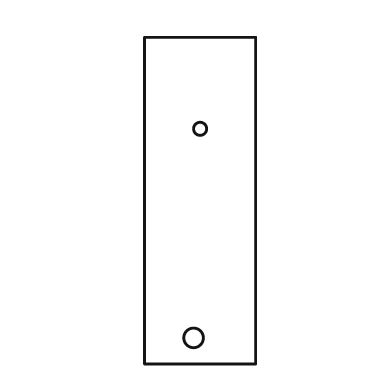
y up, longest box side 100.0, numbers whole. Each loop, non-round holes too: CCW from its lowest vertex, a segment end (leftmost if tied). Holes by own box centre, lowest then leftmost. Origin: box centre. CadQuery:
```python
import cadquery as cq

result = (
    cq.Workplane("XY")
    .moveTo(-17.0, -50.0)
    .lineTo(17.0, -50.0)
    .lineTo(17.0, 50.0)
    .lineTo(-17.0, 50.0)
    .close()
    .moveTo(-2.0, -42.0)
    .circle(3.0)
    .moveTo(0.0, 22.0)
    .circle(2.0)
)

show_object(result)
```